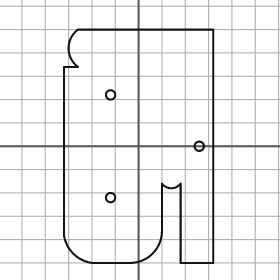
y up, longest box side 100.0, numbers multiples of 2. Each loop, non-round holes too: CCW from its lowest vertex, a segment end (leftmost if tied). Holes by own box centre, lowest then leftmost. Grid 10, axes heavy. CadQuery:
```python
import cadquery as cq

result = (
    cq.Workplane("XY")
    .moveTo(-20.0, -50.0)
    .lineTo(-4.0, -50.0)
    .threePointArc((6.0, -46.0), (10.0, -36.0))
    .lineTo(10.0, -16.0)
    .threePointArc((14.0, -18.0), (18.0, -16.0))
    .lineTo(18.0, -50.0)
    .lineTo(32.0, -50.0)
    .lineTo(32.0, 50.0)
    .lineTo(-26.0, 50.0)
    .threePointArc((-30.0, 42.0), (-26.0, 34.0))
    .lineTo(-32.0, 34.0)
    .lineTo(-32.0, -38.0)
    .threePointArc((-28.0, -46.0), (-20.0, -50.0))
    .close()
    .moveTo(-12.0, -22.0)
    .circle(2.0)
    .moveTo(26.0, 0.0)
    .circle(2.0)
    .moveTo(-12.0, 22.0)
    .circle(2.0)
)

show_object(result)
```